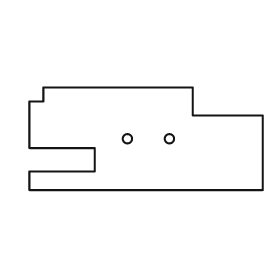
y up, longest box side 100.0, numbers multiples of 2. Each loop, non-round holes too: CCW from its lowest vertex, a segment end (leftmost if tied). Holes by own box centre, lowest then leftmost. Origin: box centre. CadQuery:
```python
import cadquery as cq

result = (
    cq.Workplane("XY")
    .moveTo(-50.0, -22.0)
    .lineTo(50.0, -22.0)
    .lineTo(50.0, 10.0)
    .lineTo(20.0, 10.0)
    .lineTo(20.0, 22.0)
    .lineTo(-44.0, 22.0)
    .lineTo(-44.0, 16.0)
    .lineTo(-50.0, 16.0)
    .lineTo(-50.0, -4.0)
    .lineTo(-22.0, -4.0)
    .lineTo(-22.0, -14.0)
    .lineTo(-50.0, -14.0)
    .close()
    .moveTo(-8.0, 0.0)
    .circle(2.0)
    .moveTo(10.0, 0.0)
    .circle(2.0)
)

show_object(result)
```